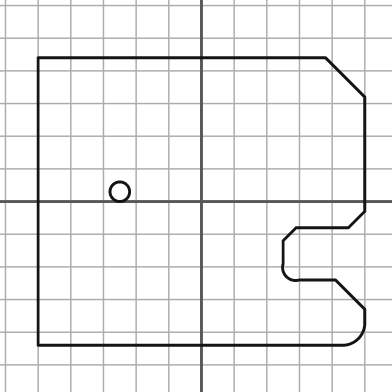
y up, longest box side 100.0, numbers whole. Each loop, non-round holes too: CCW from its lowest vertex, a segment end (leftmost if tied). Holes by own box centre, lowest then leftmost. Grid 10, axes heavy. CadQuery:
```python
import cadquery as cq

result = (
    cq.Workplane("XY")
    .moveTo(-50.0, -44.0)
    .lineTo(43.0, -44.0)
    .threePointArc((48.0, -42.0), (50.0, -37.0))
    .lineTo(50.0, -33.0)
    .lineTo(41.0, -24.0)
    .lineTo(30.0, -24.0)
    .threePointArc((26.0, -23.0), (25.0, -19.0))
    .lineTo(25.0, -12.0)
    .lineTo(29.0, -8.0)
    .lineTo(45.0, -8.0)
    .lineTo(50.0, -3.0)
    .lineTo(50.0, 32.0)
    .lineTo(38.0, 44.0)
    .lineTo(-50.0, 44.0)
    .close()
    .moveTo(-25.0, 3.0)
    .circle(3.0)
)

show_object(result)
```